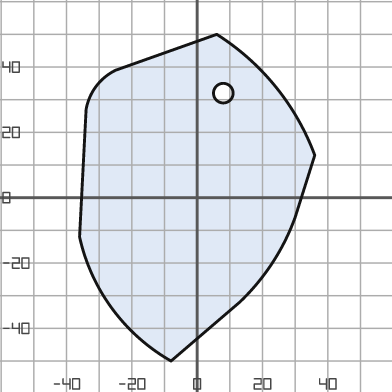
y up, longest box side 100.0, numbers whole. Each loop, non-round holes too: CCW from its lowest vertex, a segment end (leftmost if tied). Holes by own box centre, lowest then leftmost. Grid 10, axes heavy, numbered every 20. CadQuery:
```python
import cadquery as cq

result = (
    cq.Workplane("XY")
    .moveTo(-8.0, -50.0)
    .lineTo(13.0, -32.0)
    .threePointArc((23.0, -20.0), (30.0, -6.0))
    .lineTo(36.0, 13.0)
    .threePointArc((24.0, 34.0), (6.0, 50.0))
    .lineTo(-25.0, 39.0)
    .threePointArc((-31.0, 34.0), (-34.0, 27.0))
    .lineTo(-36.0, -12.0)
    .threePointArc((-26.0, -34.0), (-8.0, -50.0))
    .close()
    .moveTo(8.0, 32.0)
    .circle(3.0)
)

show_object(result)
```